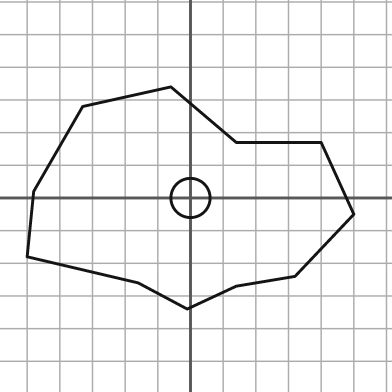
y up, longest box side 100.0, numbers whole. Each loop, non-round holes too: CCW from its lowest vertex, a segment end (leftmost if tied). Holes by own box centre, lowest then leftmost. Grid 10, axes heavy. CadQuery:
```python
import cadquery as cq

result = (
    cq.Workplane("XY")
    .moveTo(-1.0, -34.0)
    .lineTo(14.0, -27.0)
    .lineTo(32.0, -24.0)
    .lineTo(50.0, -5.0)
    .lineTo(40.0, 17.0)
    .lineTo(14.0, 17.0)
    .lineTo(-6.0, 34.0)
    .lineTo(-33.0, 28.0)
    .lineTo(-48.0, 2.0)
    .lineTo(-50.0, -18.0)
    .lineTo(-16.0, -26.0)
    .close()
    .moveTo(0.0, 0.0)
    .circle(6.0)
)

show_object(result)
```